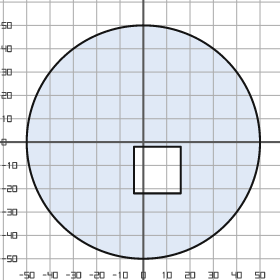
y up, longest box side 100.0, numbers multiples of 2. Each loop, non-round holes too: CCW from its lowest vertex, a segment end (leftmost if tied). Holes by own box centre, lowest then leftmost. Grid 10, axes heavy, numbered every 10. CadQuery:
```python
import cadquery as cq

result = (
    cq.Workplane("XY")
    .moveTo(0.0, 0.0)
    .circle(50.0)
    .moveTo(-4.0, -22.0)
    .lineTo(16.0, -22.0)
    .lineTo(16.0, -2.0)
    .lineTo(-4.0, -2.0)
    .close()
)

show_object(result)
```